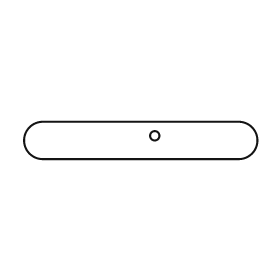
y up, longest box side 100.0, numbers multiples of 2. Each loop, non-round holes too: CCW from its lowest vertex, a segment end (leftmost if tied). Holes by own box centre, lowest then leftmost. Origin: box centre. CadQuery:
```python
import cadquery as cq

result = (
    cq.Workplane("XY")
    .moveTo(-42.0, -8.0)
    .lineTo(42.0, -8.0)
    .threePointArc((50.0, 0.0), (42.0, 8.0))
    .lineTo(-42.0, 8.0)
    .threePointArc((-50.0, 0.0), (-42.0, -8.0))
    .close()
    .moveTo(6.0, 2.0)
    .circle(2.0)
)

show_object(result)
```